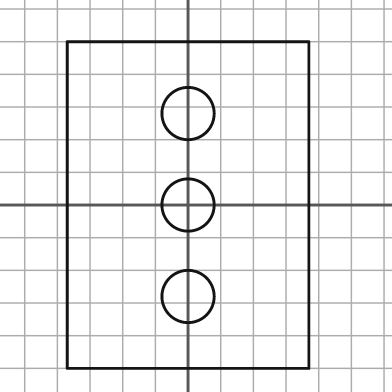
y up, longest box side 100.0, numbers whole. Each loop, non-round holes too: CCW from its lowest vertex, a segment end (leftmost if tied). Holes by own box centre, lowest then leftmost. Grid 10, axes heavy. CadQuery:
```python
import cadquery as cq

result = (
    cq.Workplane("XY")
    .moveTo(-37.0, -50.0)
    .lineTo(37.0, -50.0)
    .lineTo(37.0, 50.0)
    .lineTo(-37.0, 50.0)
    .close()
    .moveTo(0.0, -28.0)
    .circle(8.0)
    .moveTo(0.0, 0.0)
    .circle(8.0)
    .moveTo(0.0, 28.0)
    .circle(8.0)
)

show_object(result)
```